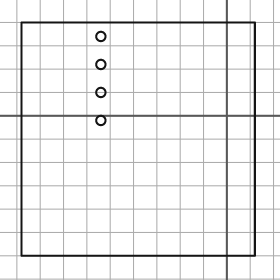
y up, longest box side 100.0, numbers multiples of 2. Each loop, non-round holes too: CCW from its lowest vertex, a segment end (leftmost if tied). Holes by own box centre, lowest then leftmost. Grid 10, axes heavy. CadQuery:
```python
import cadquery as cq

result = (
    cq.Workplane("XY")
    .moveTo(-88.0, -60.0)
    .lineTo(12.0, -60.0)
    .lineTo(12.0, 40.0)
    .lineTo(-88.0, 40.0)
    .close()
    .moveTo(-54.0, -2.0)
    .circle(2.0)
    .moveTo(-54.0, 10.0)
    .circle(2.0)
    .moveTo(-54.0, 22.0)
    .circle(2.0)
    .moveTo(-54.0, 34.0)
    .circle(2.0)
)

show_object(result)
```